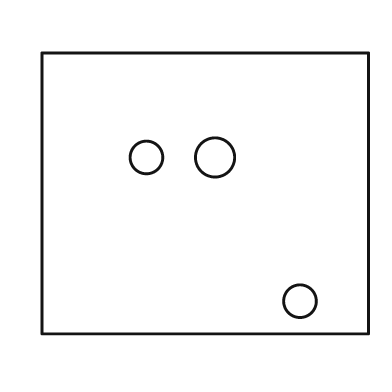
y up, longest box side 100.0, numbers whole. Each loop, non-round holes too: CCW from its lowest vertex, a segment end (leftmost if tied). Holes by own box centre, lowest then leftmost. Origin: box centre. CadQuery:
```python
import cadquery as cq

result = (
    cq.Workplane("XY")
    .moveTo(-50.0, -43.0)
    .lineTo(50.0, -43.0)
    .lineTo(50.0, 43.0)
    .lineTo(-50.0, 43.0)
    .close()
    .moveTo(29.0, -33.0)
    .circle(5.0)
    .moveTo(-18.0, 11.0)
    .circle(5.0)
    .moveTo(3.0, 11.0)
    .circle(6.0)
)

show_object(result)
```